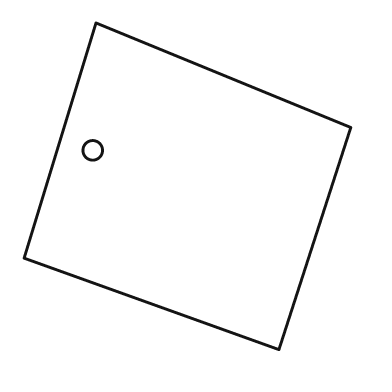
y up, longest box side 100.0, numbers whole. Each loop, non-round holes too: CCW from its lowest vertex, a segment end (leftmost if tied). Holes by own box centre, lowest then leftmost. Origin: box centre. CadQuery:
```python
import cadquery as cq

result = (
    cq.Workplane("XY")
    .moveTo(28.0, -50.0)
    .lineTo(50.0, 18.0)
    .lineTo(-28.0, 50.0)
    .lineTo(-50.0, -22.0)
    .close()
    .moveTo(-29.0, 11.0)
    .circle(3.0)
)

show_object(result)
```